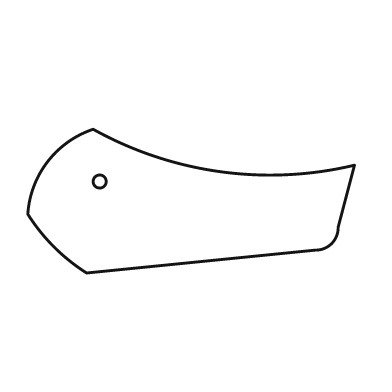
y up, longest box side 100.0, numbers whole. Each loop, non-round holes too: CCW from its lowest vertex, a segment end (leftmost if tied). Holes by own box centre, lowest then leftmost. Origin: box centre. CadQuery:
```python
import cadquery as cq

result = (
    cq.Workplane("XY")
    .moveTo(-32.0, -22.0)
    .lineTo(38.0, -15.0)
    .threePointArc((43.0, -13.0), (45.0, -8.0))
    .lineTo(50.0, 11.0)
    .threePointArc((9.0, 9.0), (-30.0, 22.0))
    .threePointArc((-44.0, 12.0), (-50.0, -4.0))
    .threePointArc((-42.0, -14.0), (-32.0, -22.0))
    .close()
    .moveTo(-28.0, 6.0)
    .circle(2.0)
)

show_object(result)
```